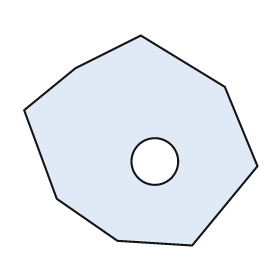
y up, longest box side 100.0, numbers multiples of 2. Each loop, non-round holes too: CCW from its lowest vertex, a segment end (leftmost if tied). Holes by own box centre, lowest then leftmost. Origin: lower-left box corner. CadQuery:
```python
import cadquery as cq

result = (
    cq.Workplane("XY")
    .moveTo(72.0, 0.0)
    .lineTo(100.0, 34.0)
    .lineTo(86.0, 68.0)
    .lineTo(50.0, 90.0)
    .lineTo(22.0, 76.0)
    .lineTo(0.0, 58.0)
    .lineTo(14.0, 20.0)
    .lineTo(40.0, 2.0)
    .close()
    .moveTo(56.0, 36.0)
    .circle(10.0)
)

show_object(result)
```